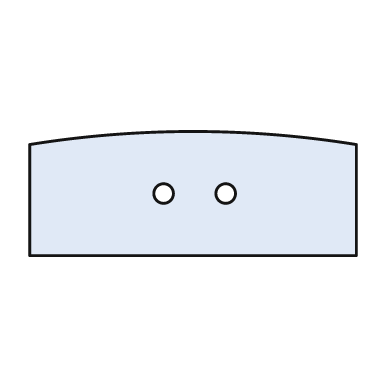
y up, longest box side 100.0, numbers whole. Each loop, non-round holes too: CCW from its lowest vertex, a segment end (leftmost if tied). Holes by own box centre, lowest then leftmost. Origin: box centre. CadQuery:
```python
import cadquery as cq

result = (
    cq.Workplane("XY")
    .moveTo(-50.0, -19.0)
    .lineTo(50.0, -19.0)
    .lineTo(50.0, 15.0)
    .threePointArc((0.0, 19.0), (-50.0, 15.0))
    .close()
    .moveTo(-9.0, 0.0)
    .circle(3.0)
    .moveTo(10.0, 0.0)
    .circle(3.0)
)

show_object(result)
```